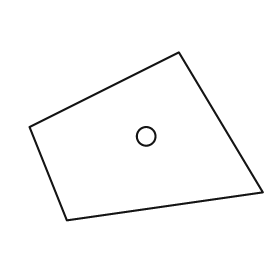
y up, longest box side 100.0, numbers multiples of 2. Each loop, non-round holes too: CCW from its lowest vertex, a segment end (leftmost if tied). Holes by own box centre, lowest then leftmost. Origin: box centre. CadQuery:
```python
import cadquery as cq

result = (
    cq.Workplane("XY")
    .moveTo(-34.0, -36.0)
    .lineTo(50.0, -24.0)
    .lineTo(14.0, 36.0)
    .lineTo(-50.0, 4.0)
    .close()
    .moveTo(0.0, 0.0)
    .circle(4.0)
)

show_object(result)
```